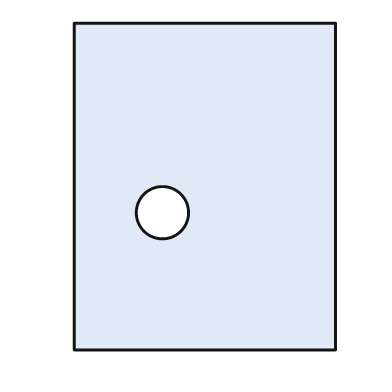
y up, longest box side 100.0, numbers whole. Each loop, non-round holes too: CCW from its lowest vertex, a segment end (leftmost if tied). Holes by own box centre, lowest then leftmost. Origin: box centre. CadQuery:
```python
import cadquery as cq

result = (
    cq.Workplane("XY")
    .moveTo(-40.0, -50.0)
    .lineTo(40.0, -50.0)
    .lineTo(40.0, 50.0)
    .lineTo(-40.0, 50.0)
    .close()
    .moveTo(-13.0, -8.0)
    .circle(8.0)
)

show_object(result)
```